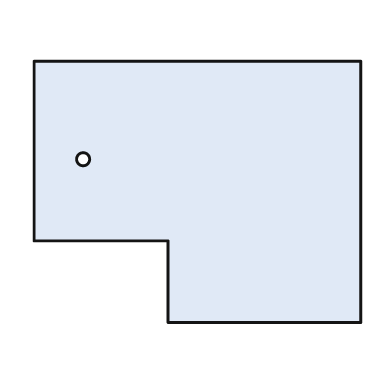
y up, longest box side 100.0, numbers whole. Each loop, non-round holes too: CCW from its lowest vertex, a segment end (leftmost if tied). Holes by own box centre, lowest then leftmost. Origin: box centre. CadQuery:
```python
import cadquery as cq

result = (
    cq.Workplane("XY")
    .moveTo(-9.0, -40.0)
    .lineTo(50.0, -40.0)
    .lineTo(50.0, 40.0)
    .lineTo(-50.0, 40.0)
    .lineTo(-50.0, -15.0)
    .lineTo(-9.0, -15.0)
    .close()
    .moveTo(-35.0, 10.0)
    .circle(2.0)
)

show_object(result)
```